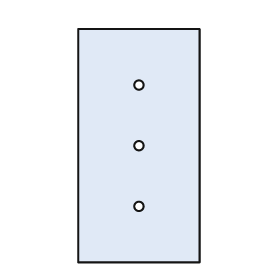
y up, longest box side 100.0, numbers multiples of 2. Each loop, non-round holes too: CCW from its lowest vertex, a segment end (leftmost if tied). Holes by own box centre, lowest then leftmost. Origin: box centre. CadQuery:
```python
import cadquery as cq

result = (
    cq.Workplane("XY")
    .moveTo(-26.0, -50.0)
    .lineTo(26.0, -50.0)
    .lineTo(26.0, 50.0)
    .lineTo(-26.0, 50.0)
    .close()
    .moveTo(0.0, -26.0)
    .circle(2.0)
    .moveTo(0.0, 0.0)
    .circle(2.0)
    .moveTo(0.0, 26.0)
    .circle(2.0)
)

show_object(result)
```